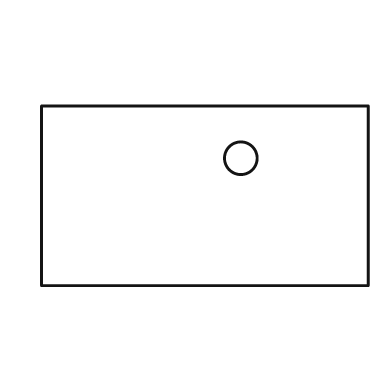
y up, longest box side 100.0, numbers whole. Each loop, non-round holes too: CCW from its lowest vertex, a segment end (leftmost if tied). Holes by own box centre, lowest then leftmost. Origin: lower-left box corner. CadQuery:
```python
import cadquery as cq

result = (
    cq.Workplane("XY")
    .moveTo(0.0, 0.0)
    .lineTo(100.0, 0.0)
    .lineTo(100.0, 55.0)
    .lineTo(0.0, 55.0)
    .close()
    .moveTo(61.0, 39.0)
    .circle(5.0)
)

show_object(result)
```